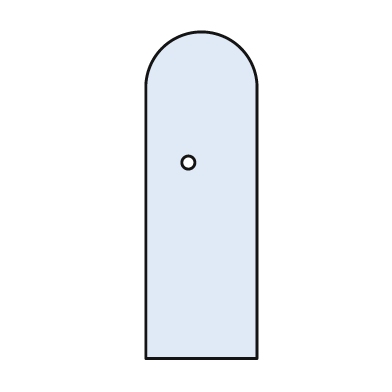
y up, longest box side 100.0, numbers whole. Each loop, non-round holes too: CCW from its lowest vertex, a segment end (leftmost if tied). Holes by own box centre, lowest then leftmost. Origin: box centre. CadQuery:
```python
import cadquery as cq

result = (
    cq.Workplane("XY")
    .moveTo(-17.0, -50.0)
    .lineTo(17.0, -50.0)
    .lineTo(17.0, 34.0)
    .threePointArc((0.0, 50.0), (-17.0, 34.0))
    .close()
    .moveTo(-4.0, 10.0)
    .circle(2.0)
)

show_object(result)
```